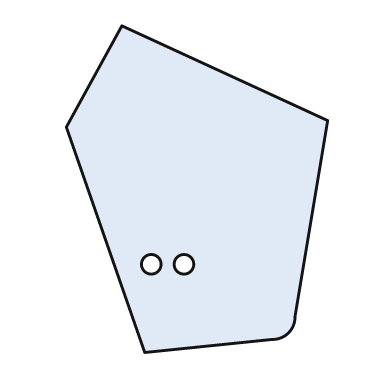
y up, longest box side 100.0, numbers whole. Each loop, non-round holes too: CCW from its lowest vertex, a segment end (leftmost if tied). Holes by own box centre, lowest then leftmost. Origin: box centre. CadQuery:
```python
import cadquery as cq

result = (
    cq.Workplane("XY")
    .moveTo(-16.0, -50.0)
    .lineTo(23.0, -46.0)
    .threePointArc((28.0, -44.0), (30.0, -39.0))
    .lineTo(40.0, 21.0)
    .lineTo(-23.0, 50.0)
    .lineTo(-40.0, 19.0)
    .close()
    .moveTo(-14.0, -23.0)
    .circle(3.0)
    .moveTo(-4.0, -23.0)
    .circle(3.0)
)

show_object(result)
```